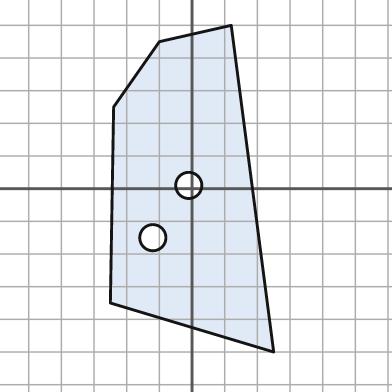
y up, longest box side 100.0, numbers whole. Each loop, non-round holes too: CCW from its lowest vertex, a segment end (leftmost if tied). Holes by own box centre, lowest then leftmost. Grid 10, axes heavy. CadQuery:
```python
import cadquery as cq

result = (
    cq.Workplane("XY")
    .moveTo(25.0, -50.0)
    .lineTo(12.0, 50.0)
    .lineTo(-10.0, 45.0)
    .lineTo(-24.0, 25.0)
    .lineTo(-25.0, -35.0)
    .close()
    .moveTo(-12.0, -15.0)
    .circle(4.0)
    .moveTo(-1.0, 1.0)
    .circle(4.0)
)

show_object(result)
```